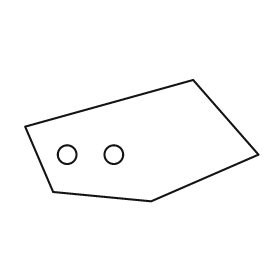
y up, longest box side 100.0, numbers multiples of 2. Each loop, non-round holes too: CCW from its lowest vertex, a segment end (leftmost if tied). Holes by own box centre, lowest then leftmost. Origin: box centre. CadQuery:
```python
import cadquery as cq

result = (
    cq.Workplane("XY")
    .moveTo(4.0, -26.0)
    .lineTo(50.0, -6.0)
    .lineTo(22.0, 26.0)
    .lineTo(-50.0, 6.0)
    .lineTo(-38.0, -22.0)
    .close()
    .moveTo(-32.0, -6.0)
    .circle(4.0)
    .moveTo(-12.0, -6.0)
    .circle(4.0)
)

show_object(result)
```